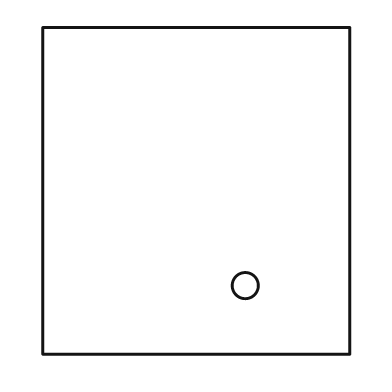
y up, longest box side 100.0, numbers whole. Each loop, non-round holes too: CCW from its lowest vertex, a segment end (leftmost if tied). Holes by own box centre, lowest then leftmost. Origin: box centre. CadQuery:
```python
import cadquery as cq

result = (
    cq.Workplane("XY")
    .moveTo(-47.0, -50.0)
    .lineTo(47.0, -50.0)
    .lineTo(47.0, 50.0)
    .lineTo(-47.0, 50.0)
    .close()
    .moveTo(15.0, -29.0)
    .circle(4.0)
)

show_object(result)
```